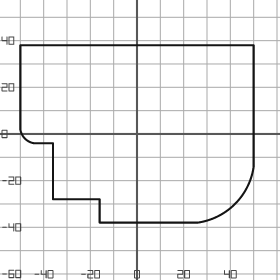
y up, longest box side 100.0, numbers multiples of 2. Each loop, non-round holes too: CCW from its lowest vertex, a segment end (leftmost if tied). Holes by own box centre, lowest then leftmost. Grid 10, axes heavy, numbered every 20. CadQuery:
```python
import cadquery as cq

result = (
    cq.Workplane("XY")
    .moveTo(-16.0, -38.0)
    .lineTo(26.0, -38.0)
    .threePointArc((42.0, -30.0), (50.0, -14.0))
    .lineTo(50.0, 38.0)
    .lineTo(-50.0, 38.0)
    .lineTo(-50.0, 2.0)
    .threePointArc((-48.0, -2.0), (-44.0, -4.0))
    .lineTo(-36.0, -4.0)
    .lineTo(-36.0, -28.0)
    .lineTo(-16.0, -28.0)
    .close()
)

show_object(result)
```